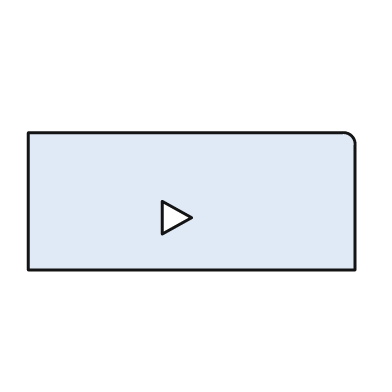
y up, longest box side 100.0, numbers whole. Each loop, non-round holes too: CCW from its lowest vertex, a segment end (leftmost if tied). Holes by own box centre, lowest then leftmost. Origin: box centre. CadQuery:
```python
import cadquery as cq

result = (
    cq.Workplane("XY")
    .moveTo(-50.0, -21.0)
    .lineTo(50.0, -21.0)
    .lineTo(50.0, 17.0)
    .threePointArc((49.0, 20.0), (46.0, 21.0))
    .lineTo(-50.0, 21.0)
    .close()
    .moveTo(-9.0, -10.0)
    .lineTo(0.0, -5.0)
    .lineTo(-9.0, 0.0)
    .close()
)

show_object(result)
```